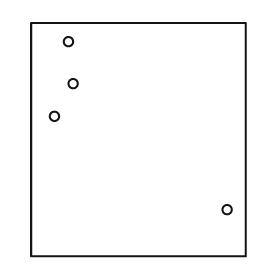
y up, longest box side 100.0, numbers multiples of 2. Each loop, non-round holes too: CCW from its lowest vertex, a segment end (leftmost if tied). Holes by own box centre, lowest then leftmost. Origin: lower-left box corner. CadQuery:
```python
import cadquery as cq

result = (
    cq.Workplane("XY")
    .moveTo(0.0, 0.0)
    .lineTo(92.0, 0.0)
    .lineTo(92.0, 100.0)
    .lineTo(0.0, 100.0)
    .close()
    .moveTo(84.0, 20.0)
    .circle(2.0)
    .moveTo(10.0, 60.0)
    .circle(2.0)
    .moveTo(18.0, 74.0)
    .circle(2.0)
    .moveTo(16.0, 92.0)
    .circle(2.0)
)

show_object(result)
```